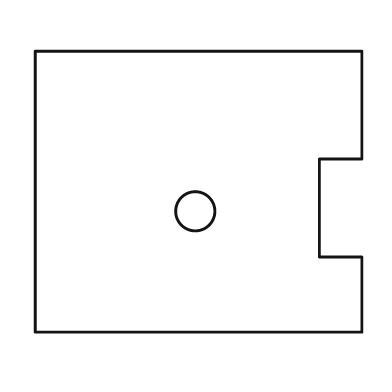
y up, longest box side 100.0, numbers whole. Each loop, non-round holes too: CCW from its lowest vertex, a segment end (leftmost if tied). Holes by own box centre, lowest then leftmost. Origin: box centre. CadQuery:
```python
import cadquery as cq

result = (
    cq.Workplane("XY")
    .moveTo(-50.0, -43.0)
    .lineTo(50.0, -43.0)
    .lineTo(50.0, -20.0)
    .lineTo(37.0, -20.0)
    .lineTo(37.0, 10.0)
    .lineTo(50.0, 10.0)
    .lineTo(50.0, 43.0)
    .lineTo(-50.0, 43.0)
    .close()
    .moveTo(-1.0, -6.0)
    .circle(6.0)
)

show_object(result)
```